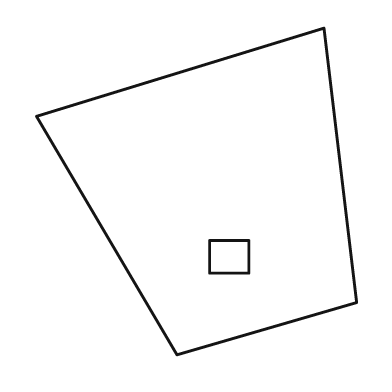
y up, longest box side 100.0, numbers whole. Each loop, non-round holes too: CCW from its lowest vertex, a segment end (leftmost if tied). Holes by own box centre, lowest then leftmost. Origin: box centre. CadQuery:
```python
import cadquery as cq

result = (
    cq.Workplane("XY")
    .moveTo(-6.0, -50.0)
    .lineTo(49.0, -34.0)
    .lineTo(39.0, 50.0)
    .lineTo(-49.0, 23.0)
    .close()
    .moveTo(4.0, -25.0)
    .lineTo(16.0, -25.0)
    .lineTo(16.0, -15.0)
    .lineTo(4.0, -15.0)
    .close()
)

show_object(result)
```